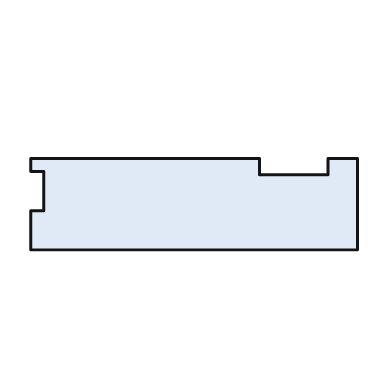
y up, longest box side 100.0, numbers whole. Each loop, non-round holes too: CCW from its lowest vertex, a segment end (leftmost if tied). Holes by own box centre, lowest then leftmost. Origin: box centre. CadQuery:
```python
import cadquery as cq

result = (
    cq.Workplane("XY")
    .moveTo(-50.0, -14.0)
    .lineTo(50.0, -14.0)
    .lineTo(50.0, 14.0)
    .lineTo(41.0, 14.0)
    .lineTo(41.0, 9.0)
    .lineTo(20.0, 9.0)
    .lineTo(20.0, 14.0)
    .lineTo(-50.0, 14.0)
    .lineTo(-50.0, 10.0)
    .lineTo(-46.0, 10.0)
    .lineTo(-46.0, -2.0)
    .lineTo(-50.0, -2.0)
    .close()
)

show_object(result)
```